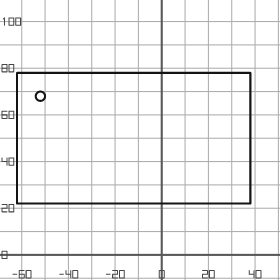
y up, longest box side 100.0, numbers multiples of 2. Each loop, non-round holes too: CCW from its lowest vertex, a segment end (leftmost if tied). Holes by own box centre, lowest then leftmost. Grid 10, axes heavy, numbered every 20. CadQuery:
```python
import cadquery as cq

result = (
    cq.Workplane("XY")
    .moveTo(-62.0, 22.0)
    .lineTo(38.0, 22.0)
    .lineTo(38.0, 78.0)
    .lineTo(-62.0, 78.0)
    .close()
    .moveTo(-52.0, 68.0)
    .circle(2.0)
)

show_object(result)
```